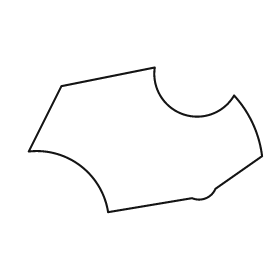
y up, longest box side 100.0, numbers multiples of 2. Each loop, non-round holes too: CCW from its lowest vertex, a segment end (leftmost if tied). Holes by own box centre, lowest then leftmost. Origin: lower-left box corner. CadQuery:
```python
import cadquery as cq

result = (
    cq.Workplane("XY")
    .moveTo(34.0, 0.0)
    .lineTo(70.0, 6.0)
    .threePointArc((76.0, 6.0), (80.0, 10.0))
    .lineTo(100.0, 24.0)
    .threePointArc((96.0, 38.0), (88.0, 50.0))
    .threePointArc((66.0, 42.0), (54.0, 62.0))
    .lineTo(14.0, 54.0)
    .lineTo(0.0, 26.0)
    .threePointArc((22.0, 20.0), (34.0, 0.0))
    .close()
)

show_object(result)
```